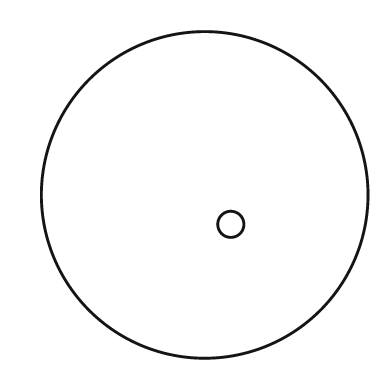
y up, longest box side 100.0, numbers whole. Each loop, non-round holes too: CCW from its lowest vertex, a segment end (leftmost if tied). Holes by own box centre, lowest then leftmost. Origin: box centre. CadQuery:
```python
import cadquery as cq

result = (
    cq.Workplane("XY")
    .moveTo(0.0, 0.0)
    .circle(50.0)
    .moveTo(8.0, -9.0)
    .circle(4.0)
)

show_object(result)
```